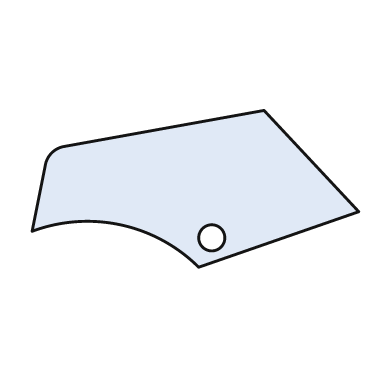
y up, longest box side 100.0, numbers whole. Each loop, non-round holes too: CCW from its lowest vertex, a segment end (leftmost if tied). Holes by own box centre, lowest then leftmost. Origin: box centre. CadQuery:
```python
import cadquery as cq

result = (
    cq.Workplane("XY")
    .moveTo(1.0, -24.0)
    .lineTo(50.0, -7.0)
    .lineTo(21.0, 24.0)
    .lineTo(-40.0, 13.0)
    .threePointArc((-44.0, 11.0), (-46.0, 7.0))
    .lineTo(-50.0, -13.0)
    .threePointArc((-23.0, -11.0), (1.0, -24.0))
    .close()
    .moveTo(5.0, -15.0)
    .circle(4.0)
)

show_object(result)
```